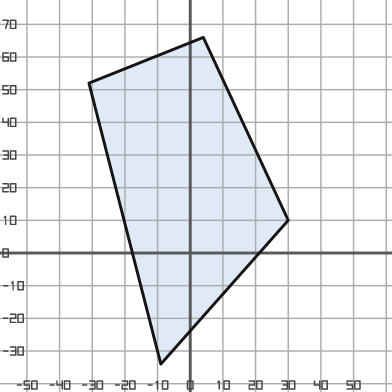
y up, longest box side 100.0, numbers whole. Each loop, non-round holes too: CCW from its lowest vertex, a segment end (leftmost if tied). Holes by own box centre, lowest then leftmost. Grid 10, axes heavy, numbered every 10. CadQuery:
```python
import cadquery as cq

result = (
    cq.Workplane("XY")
    .moveTo(-9.0, -34.0)
    .lineTo(30.0, 10.0)
    .lineTo(4.0, 66.0)
    .lineTo(-31.0, 52.0)
    .close()
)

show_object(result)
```